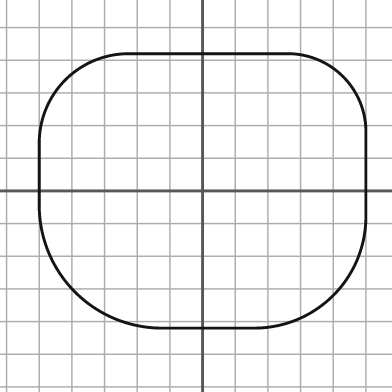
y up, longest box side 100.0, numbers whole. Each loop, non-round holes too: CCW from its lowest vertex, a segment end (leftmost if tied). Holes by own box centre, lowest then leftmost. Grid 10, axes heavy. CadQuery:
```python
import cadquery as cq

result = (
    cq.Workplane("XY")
    .moveTo(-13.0, -42.0)
    .lineTo(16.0, -42.0)
    .threePointArc((40.0, -32.0), (50.0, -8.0))
    .lineTo(50.0, 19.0)
    .threePointArc((43.0, 35.0), (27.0, 42.0))
    .lineTo(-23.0, 42.0)
    .threePointArc((-42.0, 34.0), (-50.0, 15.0))
    .lineTo(-50.0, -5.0)
    .threePointArc((-39.0, -31.0), (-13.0, -42.0))
    .close()
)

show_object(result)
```